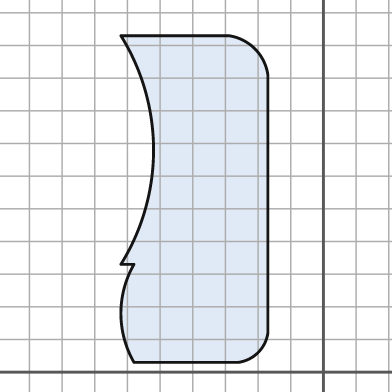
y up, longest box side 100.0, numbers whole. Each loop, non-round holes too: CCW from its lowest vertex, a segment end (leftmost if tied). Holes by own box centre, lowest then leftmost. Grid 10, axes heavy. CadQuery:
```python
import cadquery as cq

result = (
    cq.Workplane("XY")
    .moveTo(-58.0, 3.0)
    .lineTo(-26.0, 3.0)
    .threePointArc((-20.0, 6.0), (-17.0, 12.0))
    .lineTo(-17.0, 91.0)
    .threePointArc((-21.0, 99.0), (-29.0, 103.0))
    .lineTo(-62.0, 103.0)
    .threePointArc((-52.0, 68.0), (-62.0, 33.0))
    .lineTo(-58.0, 33.0)
    .threePointArc((-62.0, 18.0), (-58.0, 3.0))
    .close()
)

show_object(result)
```